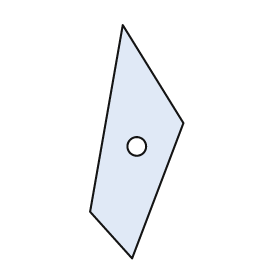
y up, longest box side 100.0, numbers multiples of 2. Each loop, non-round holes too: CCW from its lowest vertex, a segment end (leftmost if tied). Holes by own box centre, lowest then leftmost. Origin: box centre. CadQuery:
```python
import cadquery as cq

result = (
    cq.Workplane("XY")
    .moveTo(-2.0, -50.0)
    .lineTo(20.0, 8.0)
    .lineTo(-6.0, 50.0)
    .lineTo(-20.0, -30.0)
    .close()
    .moveTo(0.0, -2.0)
    .circle(4.0)
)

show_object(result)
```